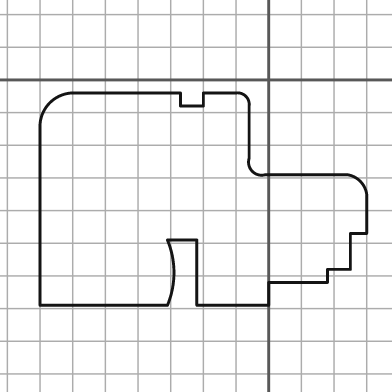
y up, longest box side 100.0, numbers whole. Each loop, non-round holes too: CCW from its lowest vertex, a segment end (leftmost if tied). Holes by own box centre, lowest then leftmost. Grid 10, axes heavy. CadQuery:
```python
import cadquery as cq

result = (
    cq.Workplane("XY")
    .moveTo(-70.0, -69.0)
    .lineTo(-31.0, -69.0)
    .threePointArc((-29.0, -59.0), (-31.0, -49.0))
    .lineTo(-22.0, -49.0)
    .lineTo(-22.0, -69.0)
    .lineTo(0.0, -69.0)
    .lineTo(0.0, -62.0)
    .lineTo(18.0, -62.0)
    .lineTo(18.0, -58.0)
    .lineTo(25.0, -58.0)
    .lineTo(25.0, -47.0)
    .lineTo(30.0, -47.0)
    .lineTo(30.0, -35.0)
    .threePointArc((28.0, -31.0), (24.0, -29.0))
    .lineTo(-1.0, -29.0)
    .threePointArc((-5.0, -28.0), (-6.0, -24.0))
    .lineTo(-6.0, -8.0)
    .threePointArc((-7.0, -5.0), (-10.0, -4.0))
    .lineTo(-20.0, -4.0)
    .lineTo(-20.0, -8.0)
    .lineTo(-27.0, -8.0)
    .lineTo(-27.0, -4.0)
    .lineTo(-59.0, -4.0)
    .threePointArc((-67.0, -7.0), (-70.0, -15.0))
    .close()
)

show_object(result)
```